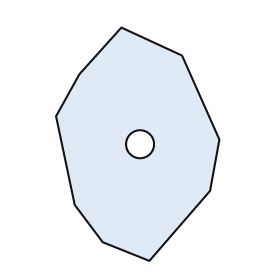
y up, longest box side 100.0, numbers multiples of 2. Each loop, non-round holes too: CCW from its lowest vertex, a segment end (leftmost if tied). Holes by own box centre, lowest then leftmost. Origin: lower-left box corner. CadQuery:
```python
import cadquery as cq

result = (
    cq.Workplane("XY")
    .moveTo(40.0, 0.0)
    .lineTo(66.0, 30.0)
    .lineTo(70.0, 52.0)
    .lineTo(54.0, 88.0)
    .lineTo(28.0, 100.0)
    .lineTo(10.0, 80.0)
    .lineTo(0.0, 62.0)
    .lineTo(8.0, 24.0)
    .lineTo(20.0, 8.0)
    .close()
    .moveTo(36.0, 50.0)
    .circle(6.0)
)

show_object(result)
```